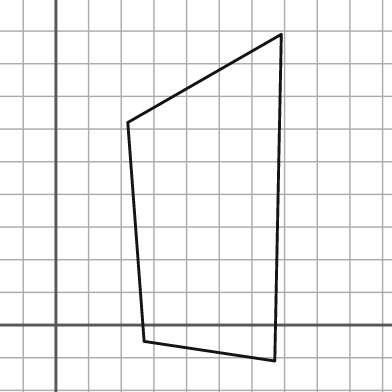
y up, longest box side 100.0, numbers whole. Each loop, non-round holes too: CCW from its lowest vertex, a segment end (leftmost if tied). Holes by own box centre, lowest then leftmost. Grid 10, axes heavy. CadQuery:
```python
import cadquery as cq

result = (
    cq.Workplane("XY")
    .moveTo(67.0, -11.0)
    .lineTo(69.0, 89.0)
    .lineTo(22.0, 62.0)
    .lineTo(27.0, -5.0)
    .close()
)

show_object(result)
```